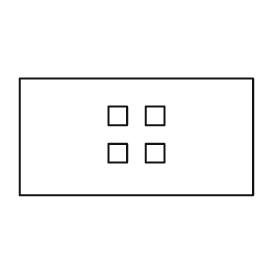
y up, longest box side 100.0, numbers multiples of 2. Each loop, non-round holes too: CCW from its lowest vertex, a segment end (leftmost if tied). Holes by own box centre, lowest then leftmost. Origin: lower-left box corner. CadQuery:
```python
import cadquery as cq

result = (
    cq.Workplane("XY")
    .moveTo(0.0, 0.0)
    .lineTo(100.0, 0.0)
    .lineTo(100.0, 50.0)
    .lineTo(0.0, 50.0)
    .close()
    .moveTo(38.0, 14.0)
    .lineTo(46.0, 14.0)
    .lineTo(46.0, 22.0)
    .lineTo(38.0, 22.0)
    .close()
    .moveTo(54.0, 14.0)
    .lineTo(62.0, 14.0)
    .lineTo(62.0, 22.0)
    .lineTo(54.0, 22.0)
    .close()
    .moveTo(38.0, 30.0)
    .lineTo(46.0, 30.0)
    .lineTo(46.0, 38.0)
    .lineTo(38.0, 38.0)
    .close()
    .moveTo(54.0, 30.0)
    .lineTo(62.0, 30.0)
    .lineTo(62.0, 38.0)
    .lineTo(54.0, 38.0)
    .close()
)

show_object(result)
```